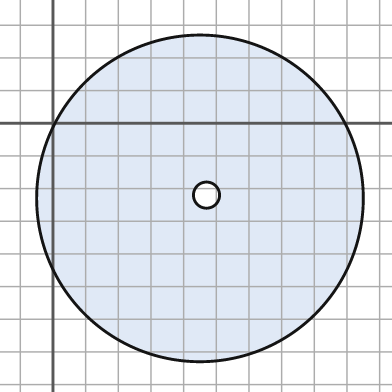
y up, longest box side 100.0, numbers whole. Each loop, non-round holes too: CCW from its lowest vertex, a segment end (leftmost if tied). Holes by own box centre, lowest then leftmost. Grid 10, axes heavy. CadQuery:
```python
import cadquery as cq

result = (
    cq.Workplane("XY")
    .moveTo(45.0, -23.0)
    .circle(50.0)
    .moveTo(47.0, -22.0)
    .circle(4.0)
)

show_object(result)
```